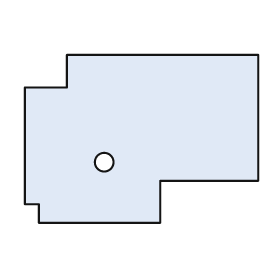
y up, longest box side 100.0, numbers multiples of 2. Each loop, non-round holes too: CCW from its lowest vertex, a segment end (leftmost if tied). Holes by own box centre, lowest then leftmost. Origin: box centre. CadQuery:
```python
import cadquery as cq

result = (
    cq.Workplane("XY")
    .moveTo(-44.0, -36.0)
    .lineTo(8.0, -36.0)
    .lineTo(8.0, -18.0)
    .lineTo(50.0, -18.0)
    .lineTo(50.0, 36.0)
    .lineTo(-32.0, 36.0)
    .lineTo(-32.0, 22.0)
    .lineTo(-50.0, 22.0)
    .lineTo(-50.0, -28.0)
    .lineTo(-44.0, -28.0)
    .close()
    .moveTo(-16.0, -10.0)
    .circle(4.0)
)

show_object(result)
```